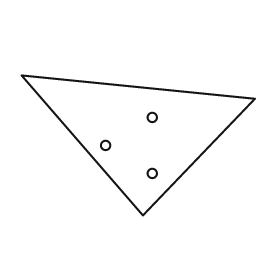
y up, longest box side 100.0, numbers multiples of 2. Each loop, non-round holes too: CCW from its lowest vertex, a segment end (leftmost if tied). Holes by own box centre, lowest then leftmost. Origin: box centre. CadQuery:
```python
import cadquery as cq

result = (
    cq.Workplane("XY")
    .moveTo(2.0, -30.0)
    .lineTo(50.0, 20.0)
    .lineTo(-50.0, 30.0)
    .close()
    .moveTo(6.0, -12.0)
    .circle(2.0)
    .moveTo(-14.0, 0.0)
    .circle(2.0)
    .moveTo(6.0, 12.0)
    .circle(2.0)
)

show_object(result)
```